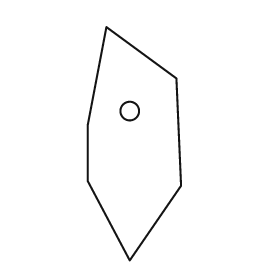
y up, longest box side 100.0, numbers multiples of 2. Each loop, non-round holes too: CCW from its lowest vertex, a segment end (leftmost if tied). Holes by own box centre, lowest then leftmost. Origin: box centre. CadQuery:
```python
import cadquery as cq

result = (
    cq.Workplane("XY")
    .moveTo(-2.0, -50.0)
    .lineTo(20.0, -18.0)
    .lineTo(18.0, 28.0)
    .lineTo(-12.0, 50.0)
    .lineTo(-20.0, 8.0)
    .lineTo(-20.0, -16.0)
    .close()
    .moveTo(-2.0, 14.0)
    .circle(4.0)
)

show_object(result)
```